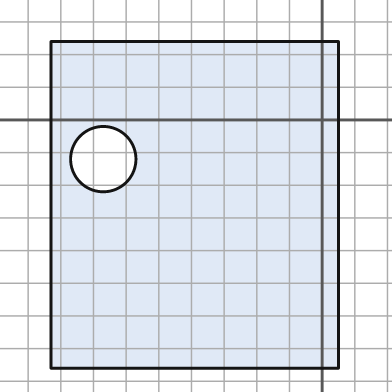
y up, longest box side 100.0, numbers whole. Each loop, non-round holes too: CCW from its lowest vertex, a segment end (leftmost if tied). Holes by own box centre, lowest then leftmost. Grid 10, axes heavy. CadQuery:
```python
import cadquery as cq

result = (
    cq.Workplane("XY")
    .moveTo(-83.0, -76.0)
    .lineTo(5.0, -76.0)
    .lineTo(5.0, 24.0)
    .lineTo(-83.0, 24.0)
    .close()
    .moveTo(-67.0, -12.0)
    .circle(10.0)
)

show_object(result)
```